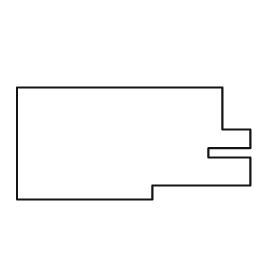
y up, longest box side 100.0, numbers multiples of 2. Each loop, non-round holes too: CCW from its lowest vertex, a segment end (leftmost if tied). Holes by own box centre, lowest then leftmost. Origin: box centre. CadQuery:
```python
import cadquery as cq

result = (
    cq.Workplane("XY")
    .moveTo(-50.0, -24.0)
    .lineTo(8.0, -24.0)
    .lineTo(8.0, -18.0)
    .lineTo(50.0, -18.0)
    .lineTo(50.0, -6.0)
    .lineTo(32.0, -6.0)
    .lineTo(32.0, -2.0)
    .lineTo(50.0, -2.0)
    .lineTo(50.0, 6.0)
    .lineTo(38.0, 6.0)
    .lineTo(38.0, 24.0)
    .lineTo(-50.0, 24.0)
    .close()
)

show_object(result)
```